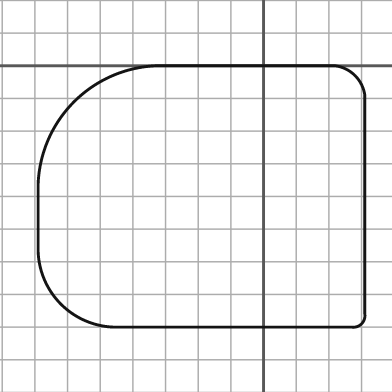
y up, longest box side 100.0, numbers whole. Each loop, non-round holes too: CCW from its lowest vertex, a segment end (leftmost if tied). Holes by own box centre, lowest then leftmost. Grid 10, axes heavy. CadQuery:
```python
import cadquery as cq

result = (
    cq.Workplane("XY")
    .moveTo(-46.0, -80.0)
    .lineTo(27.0, -80.0)
    .threePointArc((30.0, -79.0), (31.0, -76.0))
    .lineTo(31.0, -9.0)
    .threePointArc((28.0, -3.0), (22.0, 0.0))
    .lineTo(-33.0, 0.0)
    .threePointArc((-58.0, -11.0), (-69.0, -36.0))
    .lineTo(-69.0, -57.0)
    .threePointArc((-62.0, -73.0), (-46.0, -80.0))
    .close()
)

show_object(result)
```